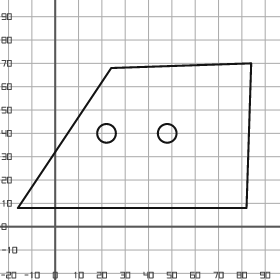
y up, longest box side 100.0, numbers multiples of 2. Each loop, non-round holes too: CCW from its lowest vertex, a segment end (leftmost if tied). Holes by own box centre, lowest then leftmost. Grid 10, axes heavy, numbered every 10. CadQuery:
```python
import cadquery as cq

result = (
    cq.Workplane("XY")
    .moveTo(-16.0, 8.0)
    .lineTo(82.0, 8.0)
    .lineTo(84.0, 70.0)
    .lineTo(24.0, 68.0)
    .close()
    .moveTo(22.0, 40.0)
    .circle(4.0)
    .moveTo(48.0, 40.0)
    .circle(4.0)
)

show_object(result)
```